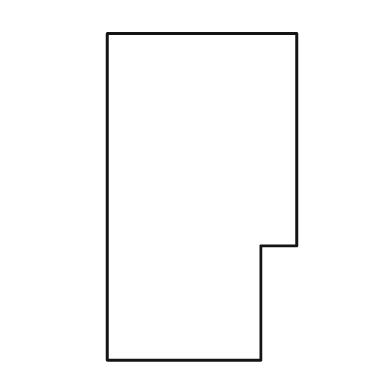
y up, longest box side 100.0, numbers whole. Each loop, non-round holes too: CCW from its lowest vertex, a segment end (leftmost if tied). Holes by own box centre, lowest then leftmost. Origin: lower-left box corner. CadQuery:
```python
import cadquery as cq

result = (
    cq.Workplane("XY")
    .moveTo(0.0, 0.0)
    .lineTo(47.0, 0.0)
    .lineTo(47.0, 35.0)
    .lineTo(58.0, 35.0)
    .lineTo(58.0, 100.0)
    .lineTo(0.0, 100.0)
    .close()
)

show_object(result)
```